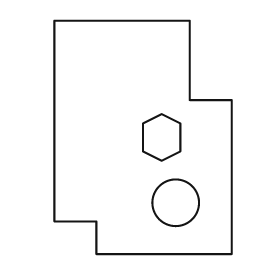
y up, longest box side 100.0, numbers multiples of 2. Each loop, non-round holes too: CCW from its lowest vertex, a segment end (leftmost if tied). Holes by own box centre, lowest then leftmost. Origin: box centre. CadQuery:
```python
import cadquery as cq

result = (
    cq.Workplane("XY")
    .moveTo(-20.0, -50.0)
    .lineTo(38.0, -50.0)
    .lineTo(38.0, 16.0)
    .lineTo(20.0, 16.0)
    .lineTo(20.0, 50.0)
    .lineTo(-38.0, 50.0)
    .lineTo(-38.0, -36.0)
    .lineTo(-20.0, -36.0)
    .close()
    .moveTo(14.0, -28.0)
    .circle(10.0)
    .moveTo(8.0, -10.0)
    .lineTo(16.0, -6.0)
    .lineTo(16.0, 6.0)
    .lineTo(8.0, 10.0)
    .lineTo(0.0, 6.0)
    .lineTo(0.0, -6.0)
    .close()
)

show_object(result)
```